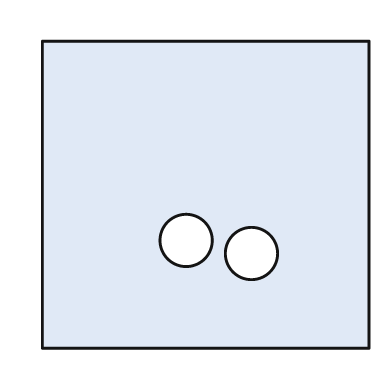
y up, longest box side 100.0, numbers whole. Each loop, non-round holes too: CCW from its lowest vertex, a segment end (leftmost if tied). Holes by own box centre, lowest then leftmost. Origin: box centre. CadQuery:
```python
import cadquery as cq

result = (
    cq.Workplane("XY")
    .moveTo(-50.0, -47.0)
    .lineTo(50.0, -47.0)
    .lineTo(50.0, 47.0)
    .lineTo(-50.0, 47.0)
    .close()
    .moveTo(14.0, -18.0)
    .circle(8.0)
    .moveTo(-6.0, -14.0)
    .circle(8.0)
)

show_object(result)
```